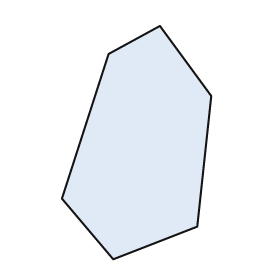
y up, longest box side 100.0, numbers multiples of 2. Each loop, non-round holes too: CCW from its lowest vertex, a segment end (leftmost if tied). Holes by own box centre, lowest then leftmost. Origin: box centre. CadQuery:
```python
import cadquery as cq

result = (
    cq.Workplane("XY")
    .moveTo(-10.0, -50.0)
    .lineTo(26.0, -36.0)
    .lineTo(32.0, 20.0)
    .lineTo(10.0, 50.0)
    .lineTo(-12.0, 38.0)
    .lineTo(-32.0, -24.0)
    .close()
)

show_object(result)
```